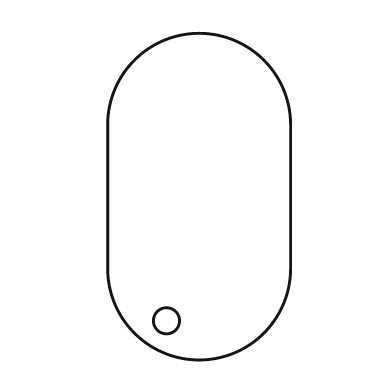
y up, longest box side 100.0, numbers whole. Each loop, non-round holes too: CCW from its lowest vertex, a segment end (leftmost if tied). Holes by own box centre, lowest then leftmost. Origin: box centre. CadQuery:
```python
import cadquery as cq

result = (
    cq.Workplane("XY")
    .moveTo(-28.0, -22.0)
    .threePointArc((0.0, -50.0), (28.0, -22.0))
    .lineTo(28.0, 22.0)
    .threePointArc((0.0, 50.0), (-28.0, 22.0))
    .close()
    .moveTo(-10.0, -38.0)
    .circle(4.0)
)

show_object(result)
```